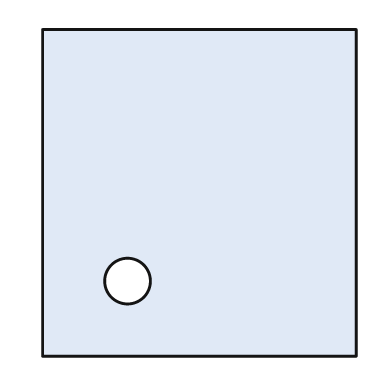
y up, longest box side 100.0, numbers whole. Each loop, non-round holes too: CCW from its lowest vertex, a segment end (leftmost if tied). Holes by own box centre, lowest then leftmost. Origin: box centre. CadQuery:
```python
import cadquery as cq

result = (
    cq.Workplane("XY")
    .moveTo(-48.0, -50.0)
    .lineTo(48.0, -50.0)
    .lineTo(48.0, 50.0)
    .lineTo(-48.0, 50.0)
    .close()
    .moveTo(-22.0, -27.0)
    .circle(7.0)
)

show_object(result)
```